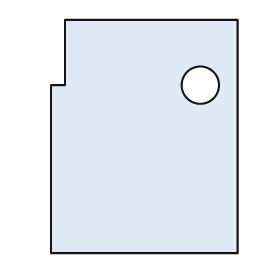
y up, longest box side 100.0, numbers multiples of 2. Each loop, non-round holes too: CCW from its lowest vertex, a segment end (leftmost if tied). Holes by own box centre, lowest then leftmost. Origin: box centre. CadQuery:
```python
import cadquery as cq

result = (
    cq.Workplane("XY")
    .moveTo(-40.0, -50.0)
    .lineTo(40.0, -50.0)
    .lineTo(40.0, 50.0)
    .lineTo(-34.0, 50.0)
    .lineTo(-34.0, 22.0)
    .lineTo(-40.0, 22.0)
    .close()
    .moveTo(24.0, 22.0)
    .circle(8.0)
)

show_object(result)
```